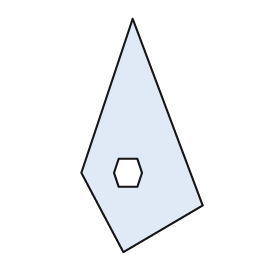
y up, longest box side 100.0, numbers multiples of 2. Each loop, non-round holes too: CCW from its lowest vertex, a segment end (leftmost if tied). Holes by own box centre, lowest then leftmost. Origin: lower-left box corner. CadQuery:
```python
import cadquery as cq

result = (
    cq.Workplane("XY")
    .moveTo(18.0, 0.0)
    .lineTo(52.0, 20.0)
    .lineTo(22.0, 100.0)
    .lineTo(0.0, 34.0)
    .close()
    .moveTo(16.0, 28.0)
    .lineTo(24.0, 28.0)
    .lineTo(26.0, 34.0)
    .lineTo(24.0, 40.0)
    .lineTo(16.0, 40.0)
    .lineTo(14.0, 34.0)
    .close()
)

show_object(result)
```